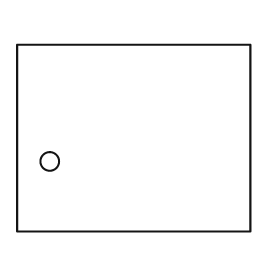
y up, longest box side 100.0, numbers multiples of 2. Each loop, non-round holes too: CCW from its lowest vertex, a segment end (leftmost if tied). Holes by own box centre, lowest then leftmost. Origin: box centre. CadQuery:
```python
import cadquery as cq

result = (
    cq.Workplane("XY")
    .moveTo(-50.0, -40.0)
    .lineTo(50.0, -40.0)
    .lineTo(50.0, 40.0)
    .lineTo(-50.0, 40.0)
    .close()
    .moveTo(-36.0, -10.0)
    .circle(4.0)
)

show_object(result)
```